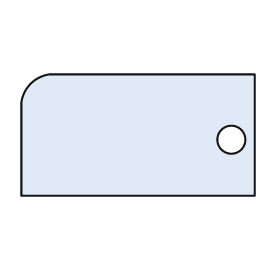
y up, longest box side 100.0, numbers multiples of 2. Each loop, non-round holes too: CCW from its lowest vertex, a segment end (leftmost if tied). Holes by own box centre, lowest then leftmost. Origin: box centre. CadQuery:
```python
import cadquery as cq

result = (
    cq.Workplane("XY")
    .moveTo(-50.0, -26.0)
    .lineTo(50.0, -26.0)
    .lineTo(50.0, 26.0)
    .lineTo(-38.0, 26.0)
    .threePointArc((-46.0, 22.0), (-50.0, 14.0))
    .close()
    .moveTo(40.0, -2.0)
    .circle(6.0)
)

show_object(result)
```